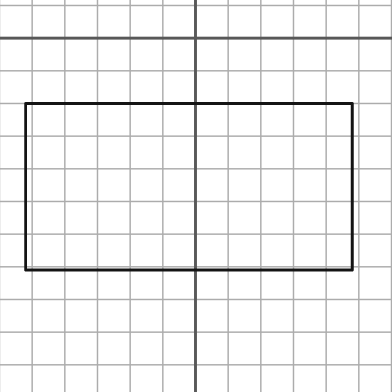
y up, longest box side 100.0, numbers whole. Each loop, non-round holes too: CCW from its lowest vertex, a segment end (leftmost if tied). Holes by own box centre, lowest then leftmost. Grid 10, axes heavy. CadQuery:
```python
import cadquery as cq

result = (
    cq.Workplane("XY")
    .moveTo(-52.0, -71.0)
    .lineTo(48.0, -71.0)
    .lineTo(48.0, -20.0)
    .lineTo(-52.0, -20.0)
    .close()
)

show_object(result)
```